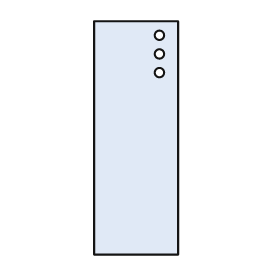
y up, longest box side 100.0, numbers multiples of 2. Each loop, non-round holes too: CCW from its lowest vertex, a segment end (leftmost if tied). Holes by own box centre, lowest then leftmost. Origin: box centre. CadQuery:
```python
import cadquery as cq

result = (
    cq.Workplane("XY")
    .moveTo(-18.0, -50.0)
    .lineTo(18.0, -50.0)
    .lineTo(18.0, 50.0)
    .lineTo(-18.0, 50.0)
    .close()
    .moveTo(10.0, 28.0)
    .circle(2.0)
    .moveTo(10.0, 36.0)
    .circle(2.0)
    .moveTo(10.0, 44.0)
    .circle(2.0)
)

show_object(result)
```